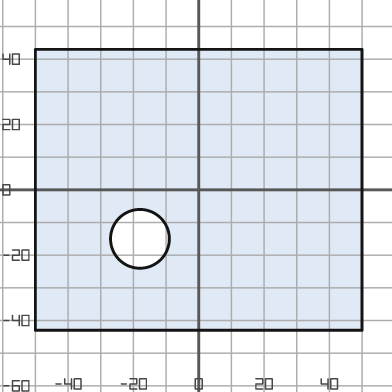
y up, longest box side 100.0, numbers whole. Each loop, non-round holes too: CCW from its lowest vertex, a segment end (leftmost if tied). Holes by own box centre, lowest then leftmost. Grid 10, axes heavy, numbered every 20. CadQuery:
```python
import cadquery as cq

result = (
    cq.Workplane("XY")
    .moveTo(-50.0, -43.0)
    .lineTo(50.0, -43.0)
    .lineTo(50.0, 43.0)
    .lineTo(-50.0, 43.0)
    .close()
    .moveTo(-18.0, -15.0)
    .circle(9.0)
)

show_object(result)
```